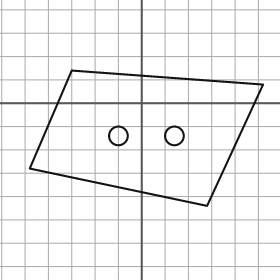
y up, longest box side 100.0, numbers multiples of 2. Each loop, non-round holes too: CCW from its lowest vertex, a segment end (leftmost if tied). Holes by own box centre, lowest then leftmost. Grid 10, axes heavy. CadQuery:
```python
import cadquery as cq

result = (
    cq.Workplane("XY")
    .moveTo(28.0, -44.0)
    .lineTo(52.0, 8.0)
    .lineTo(-30.0, 14.0)
    .lineTo(-48.0, -28.0)
    .close()
    .moveTo(-10.0, -14.0)
    .circle(4.0)
    .moveTo(14.0, -14.0)
    .circle(4.0)
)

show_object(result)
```